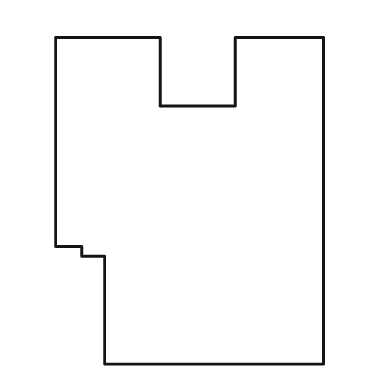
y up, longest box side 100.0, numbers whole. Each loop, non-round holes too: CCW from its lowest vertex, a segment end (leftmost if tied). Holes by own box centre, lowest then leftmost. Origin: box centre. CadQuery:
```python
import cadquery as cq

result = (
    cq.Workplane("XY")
    .moveTo(-26.0, -50.0)
    .lineTo(41.0, -50.0)
    .lineTo(41.0, 50.0)
    .lineTo(14.0, 50.0)
    .lineTo(14.0, 29.0)
    .lineTo(-9.0, 29.0)
    .lineTo(-9.0, 50.0)
    .lineTo(-41.0, 50.0)
    .lineTo(-41.0, -14.0)
    .lineTo(-33.0, -14.0)
    .lineTo(-33.0, -17.0)
    .lineTo(-26.0, -17.0)
    .close()
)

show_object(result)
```